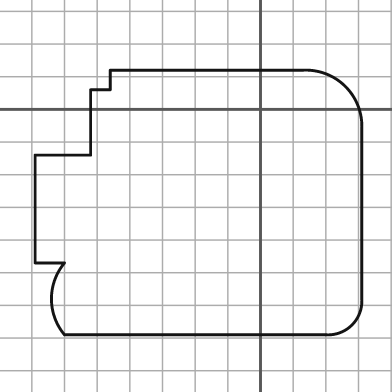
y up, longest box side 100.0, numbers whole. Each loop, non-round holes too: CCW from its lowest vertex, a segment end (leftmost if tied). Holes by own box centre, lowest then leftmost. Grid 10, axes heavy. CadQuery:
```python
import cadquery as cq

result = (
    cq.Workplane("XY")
    .moveTo(-60.0, -69.0)
    .lineTo(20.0, -69.0)
    .threePointArc((28.0, -66.0), (31.0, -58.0))
    .lineTo(31.0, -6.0)
    .threePointArc((26.0, 7.0), (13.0, 12.0))
    .lineTo(-46.0, 12.0)
    .lineTo(-46.0, 6.0)
    .lineTo(-52.0, 6.0)
    .lineTo(-52.0, -14.0)
    .lineTo(-69.0, -14.0)
    .lineTo(-69.0, -47.0)
    .lineTo(-60.0, -47.0)
    .threePointArc((-64.0, -58.0), (-60.0, -69.0))
    .close()
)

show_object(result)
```